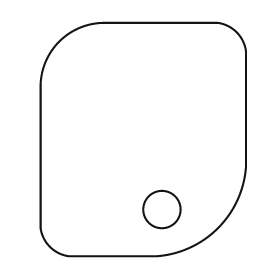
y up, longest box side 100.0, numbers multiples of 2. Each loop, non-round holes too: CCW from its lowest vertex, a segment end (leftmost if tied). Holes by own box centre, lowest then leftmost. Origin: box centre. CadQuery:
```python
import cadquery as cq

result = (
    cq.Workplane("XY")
    .moveTo(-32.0, -50.0)
    .lineTo(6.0, -50.0)
    .threePointArc((32.0, -38.0), (44.0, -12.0))
    .lineTo(44.0, 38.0)
    .threePointArc((40.0, 46.0), (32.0, 50.0))
    .lineTo(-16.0, 50.0)
    .threePointArc((-36.0, 42.0), (-44.0, 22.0))
    .lineTo(-44.0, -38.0)
    .threePointArc((-40.0, -46.0), (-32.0, -50.0))
    .close()
    .moveTo(8.0, -30.0)
    .circle(8.0)
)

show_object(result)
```